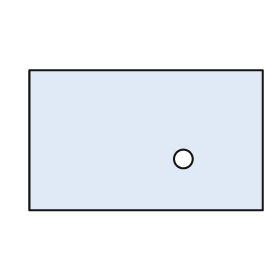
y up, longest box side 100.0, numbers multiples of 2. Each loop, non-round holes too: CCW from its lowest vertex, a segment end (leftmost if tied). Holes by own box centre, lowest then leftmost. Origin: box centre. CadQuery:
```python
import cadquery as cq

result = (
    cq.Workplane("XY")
    .moveTo(-50.0, -30.0)
    .lineTo(50.0, -30.0)
    .lineTo(50.0, 30.0)
    .lineTo(-50.0, 30.0)
    .close()
    .moveTo(16.0, -8.0)
    .circle(4.0)
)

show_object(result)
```